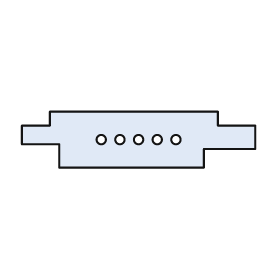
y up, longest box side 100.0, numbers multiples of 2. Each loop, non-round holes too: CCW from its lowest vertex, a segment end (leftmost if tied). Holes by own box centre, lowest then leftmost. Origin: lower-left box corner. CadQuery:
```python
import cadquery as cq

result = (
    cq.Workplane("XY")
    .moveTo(16.0, 0.0)
    .lineTo(78.0, 0.0)
    .lineTo(78.0, 8.0)
    .lineTo(100.0, 8.0)
    .lineTo(100.0, 18.0)
    .lineTo(84.0, 18.0)
    .lineTo(84.0, 24.0)
    .lineTo(12.0, 24.0)
    .lineTo(12.0, 18.0)
    .lineTo(0.0, 18.0)
    .lineTo(0.0, 10.0)
    .lineTo(16.0, 10.0)
    .close()
    .moveTo(34.0, 12.0)
    .circle(2.0)
    .moveTo(42.0, 12.0)
    .circle(2.0)
    .moveTo(50.0, 12.0)
    .circle(2.0)
    .moveTo(58.0, 12.0)
    .circle(2.0)
    .moveTo(66.0, 12.0)
    .circle(2.0)
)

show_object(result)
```